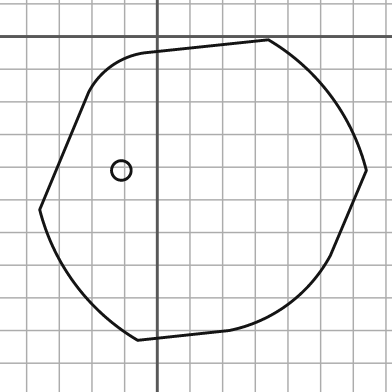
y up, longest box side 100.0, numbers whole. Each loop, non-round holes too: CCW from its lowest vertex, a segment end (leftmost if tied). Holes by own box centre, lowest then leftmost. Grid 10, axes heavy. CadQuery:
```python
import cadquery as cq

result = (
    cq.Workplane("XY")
    .moveTo(-6.0, -93.0)
    .lineTo(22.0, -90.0)
    .threePointArc((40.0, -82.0), (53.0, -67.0))
    .lineTo(64.0, -41.0)
    .threePointArc((53.0, -18.0), (34.0, -1.0))
    .lineTo(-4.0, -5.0)
    .threePointArc((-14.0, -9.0), (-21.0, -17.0))
    .lineTo(-36.0, -53.0)
    .threePointArc((-25.0, -76.0), (-6.0, -93.0))
    .close()
    .moveTo(-11.0, -41.0)
    .circle(3.0)
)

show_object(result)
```